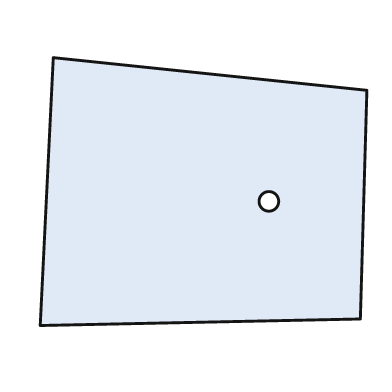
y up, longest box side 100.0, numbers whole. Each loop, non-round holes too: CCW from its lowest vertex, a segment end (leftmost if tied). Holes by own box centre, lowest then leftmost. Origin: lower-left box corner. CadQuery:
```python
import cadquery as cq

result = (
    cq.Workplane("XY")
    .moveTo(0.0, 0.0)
    .lineTo(98.0, 2.0)
    .lineTo(100.0, 72.0)
    .lineTo(4.0, 82.0)
    .close()
    .moveTo(70.0, 38.0)
    .circle(3.0)
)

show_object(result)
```